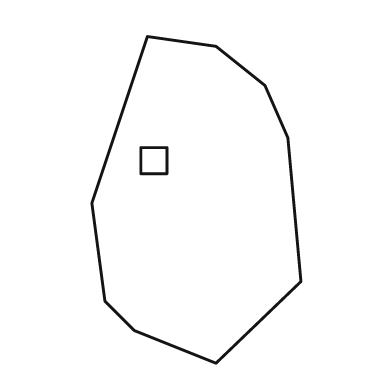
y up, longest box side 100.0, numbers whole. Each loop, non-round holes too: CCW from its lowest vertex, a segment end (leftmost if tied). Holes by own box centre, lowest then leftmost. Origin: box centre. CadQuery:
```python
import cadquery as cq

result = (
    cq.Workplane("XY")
    .moveTo(6.0, -50.0)
    .lineTo(32.0, -25.0)
    .lineTo(28.0, 19.0)
    .lineTo(21.0, 35.0)
    .lineTo(6.0, 47.0)
    .lineTo(-15.0, 50.0)
    .lineTo(-32.0, -1.0)
    .lineTo(-28.0, -31.0)
    .lineTo(-19.0, -40.0)
    .close()
    .moveTo(-17.0, 8.0)
    .lineTo(-9.0, 8.0)
    .lineTo(-9.0, 16.0)
    .lineTo(-17.0, 16.0)
    .close()
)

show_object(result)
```